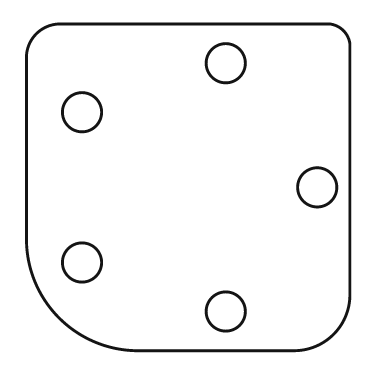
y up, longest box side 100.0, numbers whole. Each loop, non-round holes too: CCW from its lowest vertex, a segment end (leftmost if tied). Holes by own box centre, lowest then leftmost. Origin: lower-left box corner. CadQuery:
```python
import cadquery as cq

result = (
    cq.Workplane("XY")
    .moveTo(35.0, 0.0)
    .lineTo(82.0, 0.0)
    .threePointArc((94.0, 5.0), (99.0, 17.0))
    .lineTo(99.0, 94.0)
    .threePointArc((97.0, 98.0), (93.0, 100.0))
    .lineTo(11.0, 100.0)
    .threePointArc((3.0, 97.0), (0.0, 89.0))
    .lineTo(0.0, 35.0)
    .threePointArc((10.0, 10.0), (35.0, 0.0))
    .close()
    .moveTo(61.0, 12.0)
    .circle(6.0)
    .moveTo(17.0, 27.0)
    .circle(6.0)
    .moveTo(89.0, 50.0)
    .circle(6.0)
    .moveTo(17.0, 73.0)
    .circle(6.0)
    .moveTo(61.0, 88.0)
    .circle(6.0)
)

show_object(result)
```